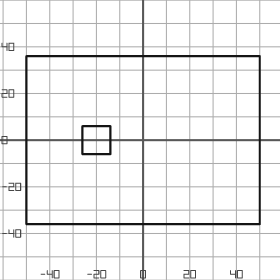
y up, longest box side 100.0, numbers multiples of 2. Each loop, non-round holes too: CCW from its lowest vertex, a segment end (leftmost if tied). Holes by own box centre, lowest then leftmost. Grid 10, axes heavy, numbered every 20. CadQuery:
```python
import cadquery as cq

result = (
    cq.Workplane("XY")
    .moveTo(-50.0, -36.0)
    .lineTo(50.0, -36.0)
    .lineTo(50.0, 36.0)
    .lineTo(-50.0, 36.0)
    .close()
    .moveTo(-26.0, -6.0)
    .lineTo(-14.0, -6.0)
    .lineTo(-14.0, 6.0)
    .lineTo(-26.0, 6.0)
    .close()
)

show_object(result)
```